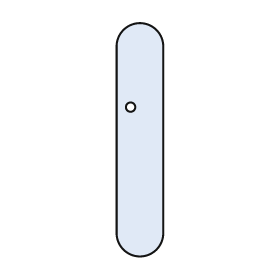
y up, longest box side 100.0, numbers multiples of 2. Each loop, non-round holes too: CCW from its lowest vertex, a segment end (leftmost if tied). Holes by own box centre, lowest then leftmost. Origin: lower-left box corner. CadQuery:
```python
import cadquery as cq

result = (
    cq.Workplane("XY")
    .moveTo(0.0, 10.0)
    .threePointArc((10.0, 0.0), (20.0, 10.0))
    .lineTo(20.0, 90.0)
    .threePointArc((10.0, 100.0), (0.0, 90.0))
    .close()
    .moveTo(6.0, 64.0)
    .circle(2.0)
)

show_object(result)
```